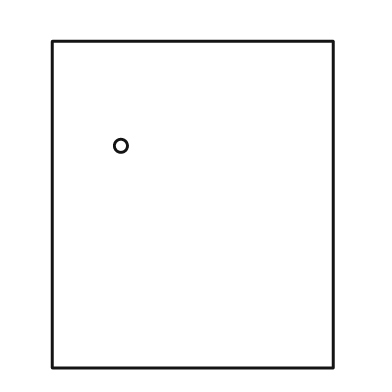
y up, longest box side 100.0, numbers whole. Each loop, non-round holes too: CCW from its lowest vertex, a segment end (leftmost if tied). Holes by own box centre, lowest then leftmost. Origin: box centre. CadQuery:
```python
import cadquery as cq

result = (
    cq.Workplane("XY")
    .moveTo(-43.0, -50.0)
    .lineTo(43.0, -50.0)
    .lineTo(43.0, 50.0)
    .lineTo(-43.0, 50.0)
    .close()
    .moveTo(-22.0, 18.0)
    .circle(2.0)
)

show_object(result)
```